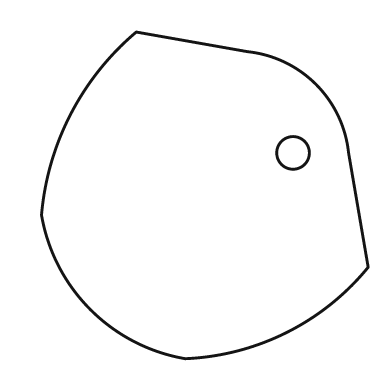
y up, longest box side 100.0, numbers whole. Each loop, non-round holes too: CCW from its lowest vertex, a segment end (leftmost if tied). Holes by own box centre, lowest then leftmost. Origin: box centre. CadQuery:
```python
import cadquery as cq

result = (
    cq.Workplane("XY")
    .moveTo(-6.0, -50.0)
    .threePointArc((25.0, -42.0), (50.0, -22.0))
    .lineTo(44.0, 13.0)
    .threePointArc((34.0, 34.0), (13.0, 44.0))
    .lineTo(-21.0, 50.0)
    .threePointArc((-41.0, 25.0), (-50.0, -6.0))
    .threePointArc((-35.0, -35.0), (-6.0, -50.0))
    .close()
    .moveTo(27.0, 13.0)
    .circle(5.0)
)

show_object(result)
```